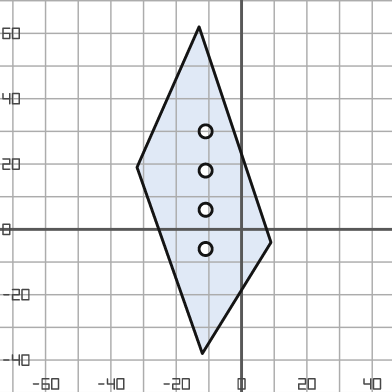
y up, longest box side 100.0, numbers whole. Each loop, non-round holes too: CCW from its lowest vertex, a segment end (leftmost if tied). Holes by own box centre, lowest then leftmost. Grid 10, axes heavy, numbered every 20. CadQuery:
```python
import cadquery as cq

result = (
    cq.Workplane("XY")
    .moveTo(-12.0, -38.0)
    .lineTo(9.0, -4.0)
    .lineTo(-13.0, 62.0)
    .lineTo(-32.0, 19.0)
    .close()
    .moveTo(-11.0, -6.0)
    .circle(2.0)
    .moveTo(-11.0, 6.0)
    .circle(2.0)
    .moveTo(-11.0, 18.0)
    .circle(2.0)
    .moveTo(-11.0, 30.0)
    .circle(2.0)
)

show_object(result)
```